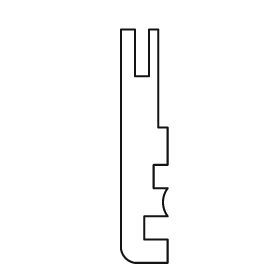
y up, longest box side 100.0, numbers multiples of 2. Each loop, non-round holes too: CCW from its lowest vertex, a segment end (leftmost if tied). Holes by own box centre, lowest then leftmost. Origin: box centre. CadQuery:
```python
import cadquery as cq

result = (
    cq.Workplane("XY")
    .moveTo(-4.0, -50.0)
    .lineTo(10.0, -50.0)
    .lineTo(10.0, -40.0)
    .lineTo(0.0, -40.0)
    .lineTo(0.0, -30.0)
    .lineTo(10.0, -30.0)
    .threePointArc((8.0, -24.0), (10.0, -18.0))
    .lineTo(4.0, -18.0)
    .lineTo(4.0, -8.0)
    .lineTo(10.0, -8.0)
    .lineTo(10.0, 8.0)
    .lineTo(6.0, 8.0)
    .lineTo(6.0, 50.0)
    .lineTo(2.0, 50.0)
    .lineTo(2.0, 30.0)
    .lineTo(-4.0, 30.0)
    .lineTo(-4.0, 50.0)
    .lineTo(-10.0, 50.0)
    .lineTo(-10.0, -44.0)
    .threePointArc((-8.0, -48.0), (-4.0, -50.0))
    .close()
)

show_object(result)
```